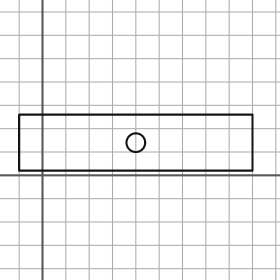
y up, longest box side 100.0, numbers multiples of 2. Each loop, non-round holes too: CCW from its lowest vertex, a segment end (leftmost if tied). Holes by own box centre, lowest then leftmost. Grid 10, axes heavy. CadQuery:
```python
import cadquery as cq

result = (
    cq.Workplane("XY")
    .moveTo(-10.0, 2.0)
    .lineTo(90.0, 2.0)
    .lineTo(90.0, 26.0)
    .lineTo(-10.0, 26.0)
    .close()
    .moveTo(40.0, 14.0)
    .circle(4.0)
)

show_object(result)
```